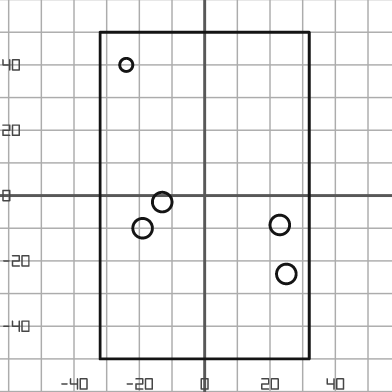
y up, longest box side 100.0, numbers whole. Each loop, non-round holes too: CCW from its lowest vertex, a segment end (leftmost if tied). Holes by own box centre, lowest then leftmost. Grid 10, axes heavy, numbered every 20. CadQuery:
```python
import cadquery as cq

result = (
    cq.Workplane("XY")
    .moveTo(-32.0, -50.0)
    .lineTo(32.0, -50.0)
    .lineTo(32.0, 50.0)
    .lineTo(-32.0, 50.0)
    .close()
    .moveTo(25.0, -24.0)
    .circle(3.0)
    .moveTo(-19.0, -10.0)
    .circle(3.0)
    .moveTo(23.0, -9.0)
    .circle(3.0)
    .moveTo(-13.0, -2.0)
    .circle(3.0)
    .moveTo(-24.0, 40.0)
    .circle(2.0)
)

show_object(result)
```